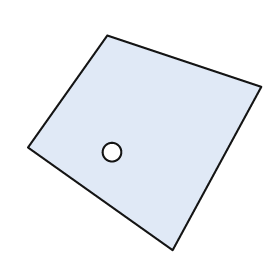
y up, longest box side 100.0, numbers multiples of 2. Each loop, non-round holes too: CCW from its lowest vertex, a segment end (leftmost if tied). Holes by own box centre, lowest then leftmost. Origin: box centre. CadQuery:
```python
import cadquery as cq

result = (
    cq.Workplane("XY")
    .moveTo(12.0, -46.0)
    .lineTo(50.0, 24.0)
    .lineTo(-16.0, 46.0)
    .lineTo(-50.0, -2.0)
    .close()
    .moveTo(-14.0, -4.0)
    .circle(4.0)
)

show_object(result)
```